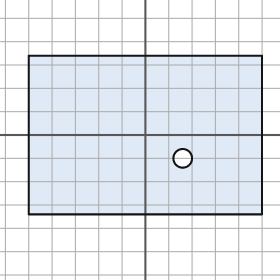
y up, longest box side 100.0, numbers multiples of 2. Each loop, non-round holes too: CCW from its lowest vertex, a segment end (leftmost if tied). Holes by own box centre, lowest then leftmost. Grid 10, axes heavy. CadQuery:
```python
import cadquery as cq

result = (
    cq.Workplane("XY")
    .moveTo(-50.0, -34.0)
    .lineTo(50.0, -34.0)
    .lineTo(50.0, 34.0)
    .lineTo(-50.0, 34.0)
    .close()
    .moveTo(16.0, -10.0)
    .circle(4.0)
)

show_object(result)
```